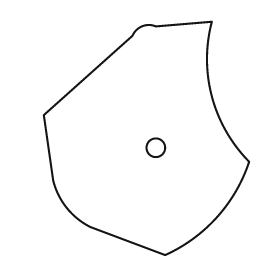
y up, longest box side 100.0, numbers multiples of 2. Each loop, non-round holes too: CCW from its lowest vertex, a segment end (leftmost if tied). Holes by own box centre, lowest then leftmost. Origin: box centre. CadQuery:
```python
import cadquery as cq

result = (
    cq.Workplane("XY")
    .moveTo(8.0, -50.0)
    .threePointArc((30.0, -34.0), (44.0, -10.0))
    .threePointArc((28.0, 18.0), (28.0, 50.0))
    .lineTo(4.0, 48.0)
    .threePointArc((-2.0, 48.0), (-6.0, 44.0))
    .lineTo(-44.0, 10.0)
    .lineTo(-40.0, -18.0)
    .threePointArc((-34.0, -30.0), (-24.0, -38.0))
    .close()
    .moveTo(4.0, -4.0)
    .circle(4.0)
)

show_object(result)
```